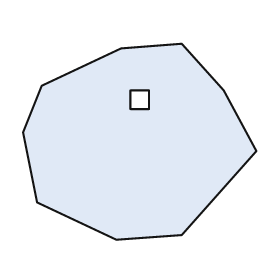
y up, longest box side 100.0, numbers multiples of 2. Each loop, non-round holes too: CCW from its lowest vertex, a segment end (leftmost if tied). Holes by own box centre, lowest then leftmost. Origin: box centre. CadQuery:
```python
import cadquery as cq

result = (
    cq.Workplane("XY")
    .moveTo(-10.0, -42.0)
    .lineTo(18.0, -40.0)
    .lineTo(50.0, -4.0)
    .lineTo(36.0, 22.0)
    .lineTo(18.0, 42.0)
    .lineTo(-8.0, 40.0)
    .lineTo(-42.0, 24.0)
    .lineTo(-50.0, 4.0)
    .lineTo(-44.0, -26.0)
    .close()
    .moveTo(-4.0, 14.0)
    .lineTo(4.0, 14.0)
    .lineTo(4.0, 22.0)
    .lineTo(-4.0, 22.0)
    .close()
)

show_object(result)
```